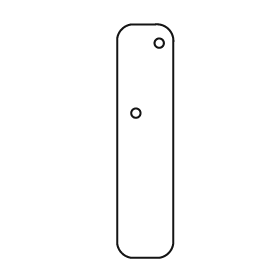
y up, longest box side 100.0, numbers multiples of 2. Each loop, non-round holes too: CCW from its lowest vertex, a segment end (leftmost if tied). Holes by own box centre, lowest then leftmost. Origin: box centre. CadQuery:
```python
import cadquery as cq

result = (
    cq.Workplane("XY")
    .moveTo(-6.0, -50.0)
    .lineTo(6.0, -50.0)
    .threePointArc((10.0, -48.0), (12.0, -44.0))
    .lineTo(12.0, 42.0)
    .threePointArc((10.0, 48.0), (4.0, 50.0))
    .lineTo(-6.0, 50.0)
    .threePointArc((-10.0, 48.0), (-12.0, 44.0))
    .lineTo(-12.0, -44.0)
    .threePointArc((-10.0, -48.0), (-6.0, -50.0))
    .close()
    .moveTo(-4.0, 12.0)
    .circle(2.0)
    .moveTo(6.0, 42.0)
    .circle(2.0)
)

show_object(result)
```